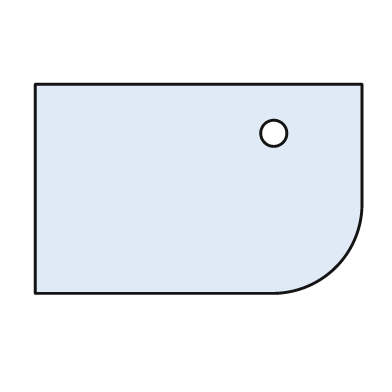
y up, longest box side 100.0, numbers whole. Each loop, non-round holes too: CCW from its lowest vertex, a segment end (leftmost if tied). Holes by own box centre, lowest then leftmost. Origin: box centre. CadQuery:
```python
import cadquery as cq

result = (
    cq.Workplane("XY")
    .moveTo(-50.0, -32.0)
    .lineTo(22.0, -32.0)
    .threePointArc((42.0, -24.0), (50.0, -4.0))
    .lineTo(50.0, 32.0)
    .lineTo(-50.0, 32.0)
    .close()
    .moveTo(23.0, 17.0)
    .circle(4.0)
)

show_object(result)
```